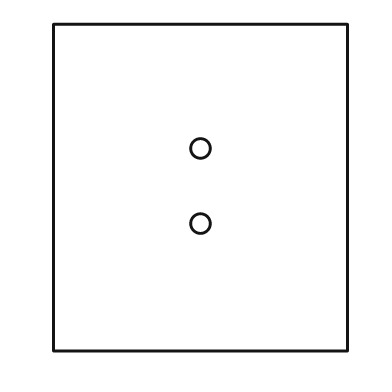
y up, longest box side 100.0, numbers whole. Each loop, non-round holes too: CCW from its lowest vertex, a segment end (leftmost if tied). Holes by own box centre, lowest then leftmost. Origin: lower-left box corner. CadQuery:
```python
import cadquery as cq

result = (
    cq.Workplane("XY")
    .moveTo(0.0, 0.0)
    .lineTo(90.0, 0.0)
    .lineTo(90.0, 100.0)
    .lineTo(0.0, 100.0)
    .close()
    .moveTo(45.0, 39.0)
    .circle(3.0)
    .moveTo(45.0, 62.0)
    .circle(3.0)
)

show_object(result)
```